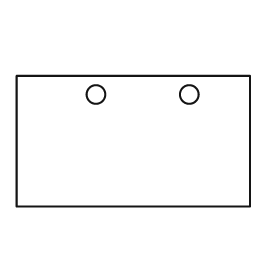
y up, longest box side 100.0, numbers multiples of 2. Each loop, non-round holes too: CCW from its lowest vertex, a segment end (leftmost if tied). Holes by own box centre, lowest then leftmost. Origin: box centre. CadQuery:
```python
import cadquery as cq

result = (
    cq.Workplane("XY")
    .moveTo(-50.0, -28.0)
    .lineTo(50.0, -28.0)
    .lineTo(50.0, 28.0)
    .lineTo(-50.0, 28.0)
    .close()
    .moveTo(-16.0, 20.0)
    .circle(4.0)
    .moveTo(24.0, 20.0)
    .circle(4.0)
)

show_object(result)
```